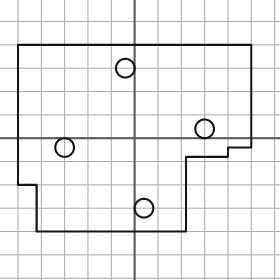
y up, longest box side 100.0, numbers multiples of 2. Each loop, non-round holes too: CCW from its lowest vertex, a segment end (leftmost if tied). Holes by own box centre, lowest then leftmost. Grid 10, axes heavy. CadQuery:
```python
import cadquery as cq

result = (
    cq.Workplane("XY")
    .moveTo(-42.0, -40.0)
    .lineTo(22.0, -40.0)
    .lineTo(22.0, -8.0)
    .lineTo(40.0, -8.0)
    .lineTo(40.0, -4.0)
    .lineTo(50.0, -4.0)
    .lineTo(50.0, 40.0)
    .lineTo(-50.0, 40.0)
    .lineTo(-50.0, -20.0)
    .lineTo(-42.0, -20.0)
    .close()
    .moveTo(4.0, -30.0)
    .circle(4.0)
    .moveTo(-30.0, -4.0)
    .circle(4.0)
    .moveTo(30.0, 4.0)
    .circle(4.0)
    .moveTo(-4.0, 30.0)
    .circle(4.0)
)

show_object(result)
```